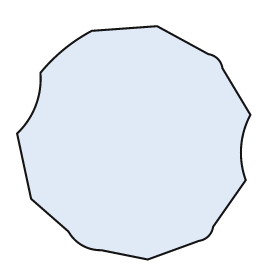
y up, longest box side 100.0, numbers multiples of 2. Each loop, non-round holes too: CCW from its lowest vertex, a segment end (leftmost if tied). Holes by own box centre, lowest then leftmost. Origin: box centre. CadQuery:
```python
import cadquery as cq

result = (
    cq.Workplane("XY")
    .moveTo(6.0, -50.0)
    .lineTo(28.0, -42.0)
    .threePointArc((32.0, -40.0), (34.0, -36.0))
    .lineTo(48.0, -16.0)
    .threePointArc((46.0, -2.0), (50.0, 12.0))
    .lineTo(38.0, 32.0)
    .threePointArc((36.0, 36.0), (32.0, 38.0))
    .lineTo(10.0, 50.0)
    .lineTo(-18.0, 48.0)
    .threePointArc((-30.0, 40.0), (-40.0, 30.0))
    .threePointArc((-42.0, 16.0), (-50.0, 4.0))
    .lineTo(-44.0, -24.0)
    .lineTo(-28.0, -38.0)
    .threePointArc((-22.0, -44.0), (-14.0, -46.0))
    .close()
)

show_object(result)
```